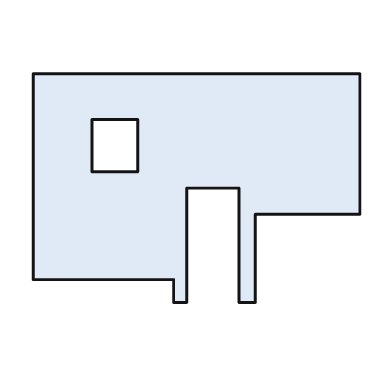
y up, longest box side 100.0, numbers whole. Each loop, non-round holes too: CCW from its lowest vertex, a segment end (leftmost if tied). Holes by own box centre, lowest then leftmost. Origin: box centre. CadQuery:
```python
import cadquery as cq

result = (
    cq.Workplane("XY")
    .moveTo(-7.0, -35.0)
    .lineTo(-3.0, -35.0)
    .lineTo(-3.0, 0.0)
    .lineTo(13.0, 0.0)
    .lineTo(13.0, -35.0)
    .lineTo(18.0, -35.0)
    .lineTo(18.0, -8.0)
    .lineTo(50.0, -8.0)
    .lineTo(50.0, 35.0)
    .lineTo(-50.0, 35.0)
    .lineTo(-50.0, -28.0)
    .lineTo(-7.0, -28.0)
    .close()
    .moveTo(-32.0, 5.0)
    .lineTo(-18.0, 5.0)
    .lineTo(-18.0, 21.0)
    .lineTo(-32.0, 21.0)
    .close()
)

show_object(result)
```